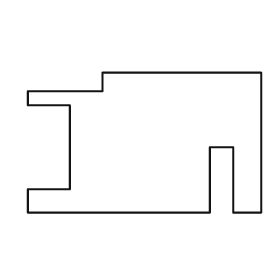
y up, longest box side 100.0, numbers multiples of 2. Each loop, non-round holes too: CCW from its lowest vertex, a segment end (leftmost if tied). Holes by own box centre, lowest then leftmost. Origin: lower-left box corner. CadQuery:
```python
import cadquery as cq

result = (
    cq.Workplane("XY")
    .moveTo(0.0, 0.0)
    .lineTo(78.0, 0.0)
    .lineTo(78.0, 28.0)
    .lineTo(88.0, 28.0)
    .lineTo(88.0, 0.0)
    .lineTo(100.0, 0.0)
    .lineTo(100.0, 60.0)
    .lineTo(32.0, 60.0)
    .lineTo(32.0, 52.0)
    .lineTo(0.0, 52.0)
    .lineTo(0.0, 46.0)
    .lineTo(18.0, 46.0)
    .lineTo(18.0, 10.0)
    .lineTo(0.0, 10.0)
    .close()
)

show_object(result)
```